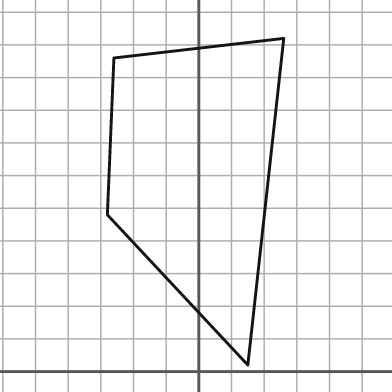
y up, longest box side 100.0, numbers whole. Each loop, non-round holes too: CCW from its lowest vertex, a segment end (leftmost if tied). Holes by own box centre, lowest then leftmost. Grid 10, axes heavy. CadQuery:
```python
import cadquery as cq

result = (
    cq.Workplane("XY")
    .moveTo(15.0, 2.0)
    .lineTo(26.0, 102.0)
    .lineTo(-26.0, 96.0)
    .lineTo(-28.0, 48.0)
    .close()
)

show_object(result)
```